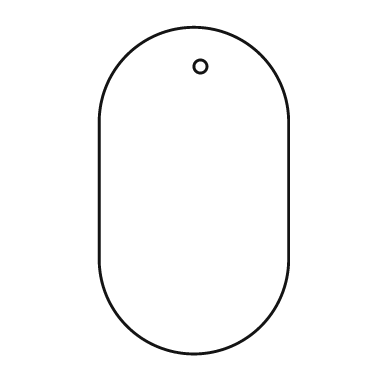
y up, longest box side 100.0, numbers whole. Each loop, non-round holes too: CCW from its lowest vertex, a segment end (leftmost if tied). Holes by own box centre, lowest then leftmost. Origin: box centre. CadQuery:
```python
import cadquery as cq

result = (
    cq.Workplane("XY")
    .moveTo(-29.0, -21.0)
    .threePointArc((0.0, -50.0), (29.0, -21.0))
    .lineTo(29.0, 21.0)
    .threePointArc((0.0, 50.0), (-29.0, 21.0))
    .close()
    .moveTo(2.0, 38.0)
    .circle(2.0)
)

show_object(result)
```